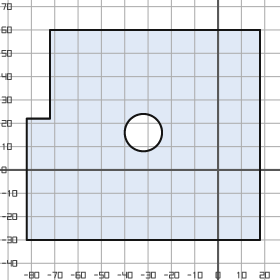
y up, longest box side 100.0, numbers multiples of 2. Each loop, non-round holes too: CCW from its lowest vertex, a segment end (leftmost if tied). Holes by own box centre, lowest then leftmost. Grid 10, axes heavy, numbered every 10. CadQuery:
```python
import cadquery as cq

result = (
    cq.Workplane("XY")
    .moveTo(-82.0, -30.0)
    .lineTo(18.0, -30.0)
    .lineTo(18.0, 60.0)
    .lineTo(-72.0, 60.0)
    .lineTo(-72.0, 22.0)
    .lineTo(-82.0, 22.0)
    .close()
    .moveTo(-32.0, 16.0)
    .circle(8.0)
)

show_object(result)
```